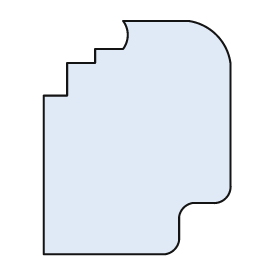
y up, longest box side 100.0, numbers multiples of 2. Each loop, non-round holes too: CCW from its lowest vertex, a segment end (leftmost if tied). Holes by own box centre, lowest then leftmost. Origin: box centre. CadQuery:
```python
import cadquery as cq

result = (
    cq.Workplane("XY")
    .moveTo(-40.0, -50.0)
    .lineTo(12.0, -50.0)
    .threePointArc((16.0, -48.0), (18.0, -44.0))
    .lineTo(18.0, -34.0)
    .threePointArc((20.0, -30.0), (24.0, -28.0))
    .lineTo(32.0, -28.0)
    .threePointArc((38.0, -26.0), (40.0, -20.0))
    .lineTo(40.0, 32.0)
    .threePointArc((34.0, 44.0), (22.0, 50.0))
    .lineTo(-6.0, 50.0)
    .threePointArc((-4.0, 44.0), (-6.0, 38.0))
    .lineTo(-18.0, 38.0)
    .lineTo(-18.0, 32.0)
    .lineTo(-30.0, 32.0)
    .lineTo(-30.0, 18.0)
    .lineTo(-40.0, 18.0)
    .close()
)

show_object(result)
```